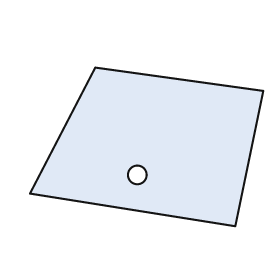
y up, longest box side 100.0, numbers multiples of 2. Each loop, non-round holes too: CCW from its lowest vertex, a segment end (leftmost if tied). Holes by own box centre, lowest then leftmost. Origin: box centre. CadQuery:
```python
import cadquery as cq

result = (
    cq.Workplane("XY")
    .moveTo(38.0, -34.0)
    .lineTo(50.0, 24.0)
    .lineTo(-22.0, 34.0)
    .lineTo(-50.0, -20.0)
    .close()
    .moveTo(-4.0, -12.0)
    .circle(4.0)
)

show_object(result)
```